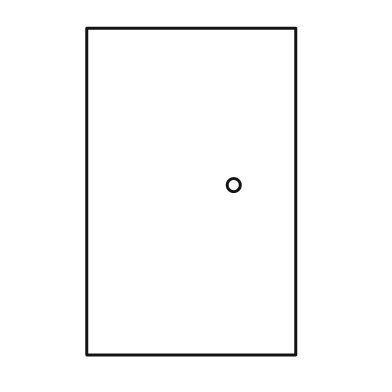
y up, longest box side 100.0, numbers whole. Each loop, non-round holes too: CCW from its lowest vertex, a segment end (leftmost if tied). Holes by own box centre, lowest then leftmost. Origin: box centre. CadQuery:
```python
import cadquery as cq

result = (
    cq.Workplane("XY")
    .moveTo(-32.0, -50.0)
    .lineTo(32.0, -50.0)
    .lineTo(32.0, 50.0)
    .lineTo(-32.0, 50.0)
    .close()
    .moveTo(13.0, 2.0)
    .circle(2.0)
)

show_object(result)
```